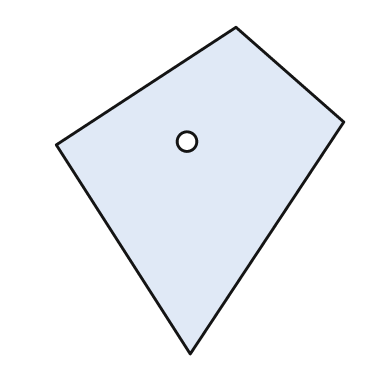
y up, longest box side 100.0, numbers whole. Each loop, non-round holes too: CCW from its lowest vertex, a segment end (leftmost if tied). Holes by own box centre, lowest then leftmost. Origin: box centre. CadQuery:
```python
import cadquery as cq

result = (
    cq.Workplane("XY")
    .moveTo(-3.0, -50.0)
    .lineTo(44.0, 21.0)
    .lineTo(11.0, 50.0)
    .lineTo(-44.0, 14.0)
    .close()
    .moveTo(-4.0, 15.0)
    .circle(3.0)
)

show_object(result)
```